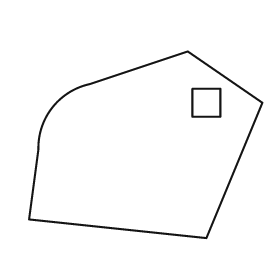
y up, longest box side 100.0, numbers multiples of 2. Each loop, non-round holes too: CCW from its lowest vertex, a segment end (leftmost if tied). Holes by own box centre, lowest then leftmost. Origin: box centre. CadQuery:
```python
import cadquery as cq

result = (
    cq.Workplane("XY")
    .moveTo(26.0, -40.0)
    .lineTo(50.0, 18.0)
    .lineTo(18.0, 40.0)
    .lineTo(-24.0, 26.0)
    .threePointArc((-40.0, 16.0), (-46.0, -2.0))
    .lineTo(-50.0, -32.0)
    .close()
    .moveTo(20.0, 12.0)
    .lineTo(32.0, 12.0)
    .lineTo(32.0, 24.0)
    .lineTo(20.0, 24.0)
    .close()
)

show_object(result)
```